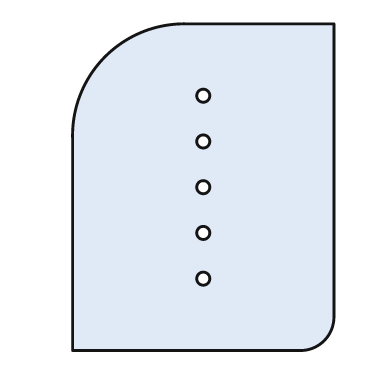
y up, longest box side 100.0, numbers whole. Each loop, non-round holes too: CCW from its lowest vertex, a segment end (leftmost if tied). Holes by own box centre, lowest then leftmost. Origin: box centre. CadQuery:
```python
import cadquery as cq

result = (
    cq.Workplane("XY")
    .moveTo(-40.0, -50.0)
    .lineTo(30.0, -50.0)
    .threePointArc((37.0, -47.0), (40.0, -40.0))
    .lineTo(40.0, 50.0)
    .lineTo(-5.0, 50.0)
    .threePointArc((-30.0, 40.0), (-40.0, 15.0))
    .close()
    .moveTo(0.0, -28.0)
    .circle(2.0)
    .moveTo(0.0, -14.0)
    .circle(2.0)
    .moveTo(0.0, 0.0)
    .circle(2.0)
    .moveTo(0.0, 14.0)
    .circle(2.0)
    .moveTo(0.0, 28.0)
    .circle(2.0)
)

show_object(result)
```